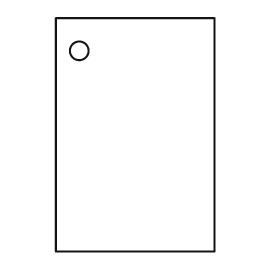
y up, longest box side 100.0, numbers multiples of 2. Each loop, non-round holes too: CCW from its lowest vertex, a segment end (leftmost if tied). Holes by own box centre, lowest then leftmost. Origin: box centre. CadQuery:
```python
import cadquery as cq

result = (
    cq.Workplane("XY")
    .moveTo(-34.0, -50.0)
    .lineTo(34.0, -50.0)
    .lineTo(34.0, 50.0)
    .lineTo(-34.0, 50.0)
    .close()
    .moveTo(-24.0, 36.0)
    .circle(4.0)
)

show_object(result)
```